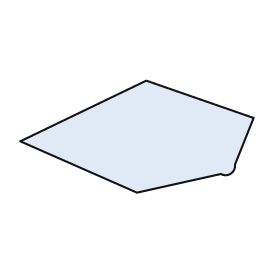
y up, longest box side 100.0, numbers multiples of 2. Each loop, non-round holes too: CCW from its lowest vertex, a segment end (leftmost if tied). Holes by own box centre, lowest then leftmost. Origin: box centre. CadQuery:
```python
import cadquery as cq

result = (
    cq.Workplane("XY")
    .moveTo(0.0, -24.0)
    .lineTo(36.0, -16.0)
    .threePointArc((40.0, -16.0), (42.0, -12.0))
    .lineTo(50.0, 8.0)
    .lineTo(4.0, 24.0)
    .lineTo(-50.0, -2.0)
    .close()
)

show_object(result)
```